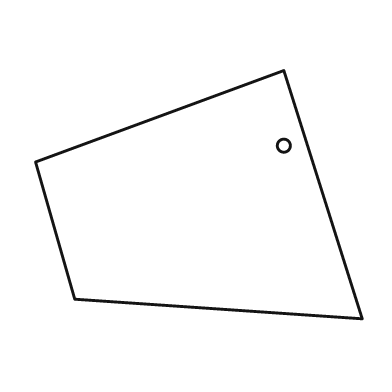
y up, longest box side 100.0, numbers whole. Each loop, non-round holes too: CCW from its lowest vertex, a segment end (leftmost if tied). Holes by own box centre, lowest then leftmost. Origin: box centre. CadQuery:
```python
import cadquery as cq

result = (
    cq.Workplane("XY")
    .moveTo(50.0, -38.0)
    .lineTo(26.0, 38.0)
    .lineTo(-50.0, 10.0)
    .lineTo(-38.0, -32.0)
    .close()
    .moveTo(26.0, 15.0)
    .circle(2.0)
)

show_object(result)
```